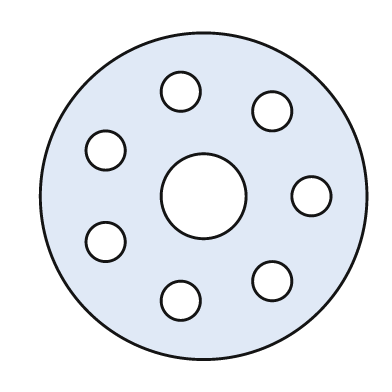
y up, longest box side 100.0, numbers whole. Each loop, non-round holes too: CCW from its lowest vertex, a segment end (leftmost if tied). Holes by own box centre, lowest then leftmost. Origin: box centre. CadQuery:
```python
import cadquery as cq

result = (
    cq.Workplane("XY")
    .moveTo(0.0, 0.0)
    .circle(50.0)
    .moveTo(-7.0, -32.0)
    .circle(6.0)
    .moveTo(21.0, -26.0)
    .circle(6.0)
    .moveTo(-30.0, -14.0)
    .circle(6.0)
    .moveTo(0.0, 0.0)
    .circle(13.0)
    .moveTo(33.0, 0.0)
    .circle(6.0)
    .moveTo(-30.0, 14.0)
    .circle(6.0)
    .moveTo(21.0, 26.0)
    .circle(6.0)
    .moveTo(-7.0, 32.0)
    .circle(6.0)
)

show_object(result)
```